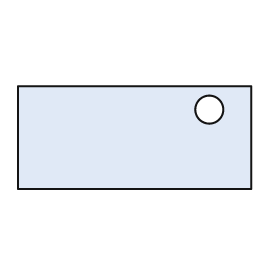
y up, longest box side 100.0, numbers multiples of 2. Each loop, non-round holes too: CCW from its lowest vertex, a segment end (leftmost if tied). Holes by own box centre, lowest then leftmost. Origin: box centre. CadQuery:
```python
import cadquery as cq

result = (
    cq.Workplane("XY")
    .moveTo(-50.0, -22.0)
    .lineTo(50.0, -22.0)
    .lineTo(50.0, 22.0)
    .lineTo(-50.0, 22.0)
    .close()
    .moveTo(32.0, 12.0)
    .circle(6.0)
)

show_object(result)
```